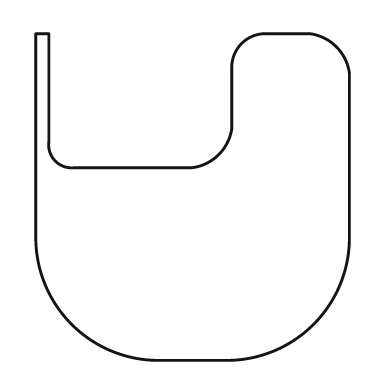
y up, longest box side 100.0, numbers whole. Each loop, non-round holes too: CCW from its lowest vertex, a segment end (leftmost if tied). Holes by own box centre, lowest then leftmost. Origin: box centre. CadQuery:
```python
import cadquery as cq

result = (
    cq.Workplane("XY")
    .moveTo(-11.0, -50.0)
    .lineTo(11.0, -50.0)
    .threePointArc((37.0, -39.0), (48.0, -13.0))
    .lineTo(48.0, 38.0)
    .threePointArc((44.0, 46.0), (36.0, 50.0))
    .lineTo(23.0, 50.0)
    .threePointArc((15.0, 47.0), (12.0, 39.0))
    .lineTo(12.0, 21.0)
    .threePointArc((8.0, 13.0), (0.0, 9.0))
    .lineTo(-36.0, 9.0)
    .threePointArc((-42.0, 11.0), (-44.0, 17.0))
    .lineTo(-44.0, 50.0)
    .lineTo(-48.0, 50.0)
    .lineTo(-48.0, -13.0)
    .threePointArc((-37.0, -39.0), (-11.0, -50.0))
    .close()
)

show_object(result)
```